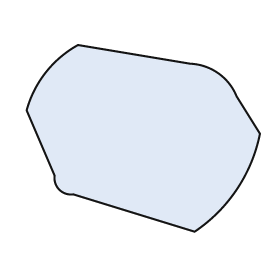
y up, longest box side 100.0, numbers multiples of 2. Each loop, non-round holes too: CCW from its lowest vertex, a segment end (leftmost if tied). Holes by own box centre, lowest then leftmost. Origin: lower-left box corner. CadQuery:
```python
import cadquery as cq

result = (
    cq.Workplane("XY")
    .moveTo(72.0, 0.0)
    .threePointArc((90.0, 18.0), (100.0, 42.0))
    .lineTo(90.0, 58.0)
    .threePointArc((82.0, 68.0), (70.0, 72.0))
    .lineTo(22.0, 80.0)
    .threePointArc((8.0, 68.0), (0.0, 52.0))
    .lineTo(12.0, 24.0)
    .threePointArc((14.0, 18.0), (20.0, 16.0))
    .close()
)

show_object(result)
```